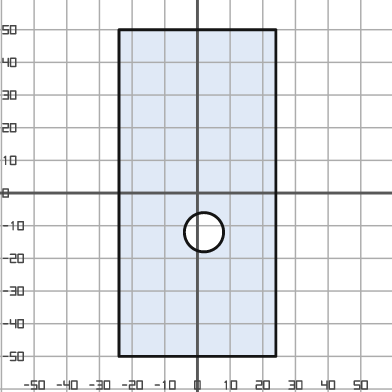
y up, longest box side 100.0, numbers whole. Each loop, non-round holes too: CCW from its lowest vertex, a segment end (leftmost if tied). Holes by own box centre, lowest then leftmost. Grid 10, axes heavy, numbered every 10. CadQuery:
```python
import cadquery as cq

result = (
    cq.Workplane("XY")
    .moveTo(-24.0, -50.0)
    .lineTo(24.0, -50.0)
    .lineTo(24.0, 50.0)
    .lineTo(-24.0, 50.0)
    .close()
    .moveTo(2.0, -12.0)
    .circle(6.0)
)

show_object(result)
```